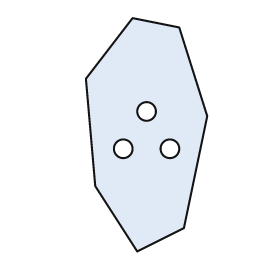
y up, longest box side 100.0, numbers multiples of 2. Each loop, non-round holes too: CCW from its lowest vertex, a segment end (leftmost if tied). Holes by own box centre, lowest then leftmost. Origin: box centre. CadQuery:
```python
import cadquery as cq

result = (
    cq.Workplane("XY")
    .moveTo(-4.0, -50.0)
    .lineTo(16.0, -40.0)
    .lineTo(26.0, 8.0)
    .lineTo(14.0, 46.0)
    .lineTo(-6.0, 50.0)
    .lineTo(-26.0, 24.0)
    .lineTo(-22.0, -22.0)
    .close()
    .moveTo(-10.0, -6.0)
    .circle(4.0)
    .moveTo(10.0, -6.0)
    .circle(4.0)
    .moveTo(0.0, 10.0)
    .circle(4.0)
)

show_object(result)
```